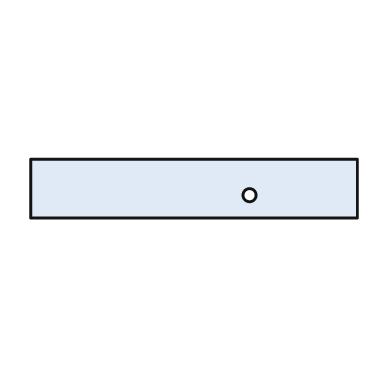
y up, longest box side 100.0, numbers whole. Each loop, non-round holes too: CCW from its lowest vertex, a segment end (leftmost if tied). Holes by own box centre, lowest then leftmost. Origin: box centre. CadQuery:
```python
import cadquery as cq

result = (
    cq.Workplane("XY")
    .moveTo(-50.0, -9.0)
    .lineTo(50.0, -9.0)
    .lineTo(50.0, 9.0)
    .lineTo(-50.0, 9.0)
    .close()
    .moveTo(17.0, -2.0)
    .circle(2.0)
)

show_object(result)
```